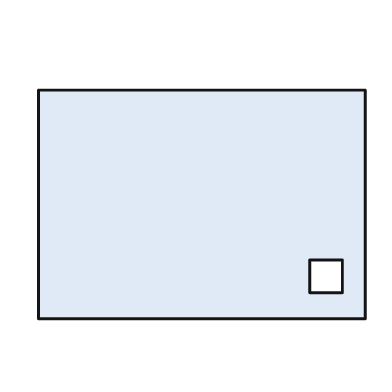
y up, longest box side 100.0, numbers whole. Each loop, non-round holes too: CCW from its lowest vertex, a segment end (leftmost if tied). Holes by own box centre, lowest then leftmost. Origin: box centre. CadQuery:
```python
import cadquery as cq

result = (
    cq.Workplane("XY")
    .moveTo(-50.0, -35.0)
    .lineTo(50.0, -35.0)
    .lineTo(50.0, 35.0)
    .lineTo(-50.0, 35.0)
    .close()
    .moveTo(33.0, -27.0)
    .lineTo(43.0, -27.0)
    .lineTo(43.0, -17.0)
    .lineTo(33.0, -17.0)
    .close()
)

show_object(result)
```